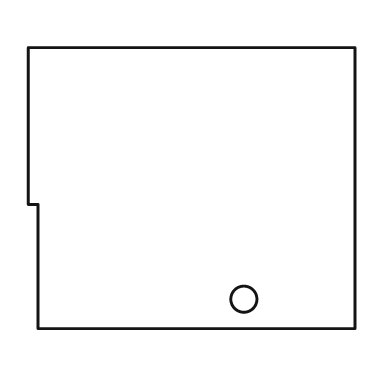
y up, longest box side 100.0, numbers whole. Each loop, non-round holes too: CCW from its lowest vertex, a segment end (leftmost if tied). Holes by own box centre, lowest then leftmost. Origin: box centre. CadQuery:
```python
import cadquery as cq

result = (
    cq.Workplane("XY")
    .moveTo(-47.0, -43.0)
    .lineTo(50.0, -43.0)
    .lineTo(50.0, 43.0)
    .lineTo(-50.0, 43.0)
    .lineTo(-50.0, -5.0)
    .lineTo(-47.0, -5.0)
    .close()
    .moveTo(16.0, -34.0)
    .circle(4.0)
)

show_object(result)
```